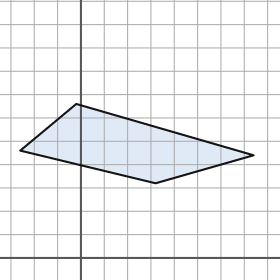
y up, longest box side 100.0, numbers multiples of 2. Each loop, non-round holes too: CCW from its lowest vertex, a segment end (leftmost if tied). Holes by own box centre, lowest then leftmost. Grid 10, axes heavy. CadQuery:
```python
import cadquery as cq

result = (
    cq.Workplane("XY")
    .moveTo(32.0, 32.0)
    .lineTo(74.0, 44.0)
    .lineTo(-2.0, 66.0)
    .lineTo(-26.0, 46.0)
    .close()
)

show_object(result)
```